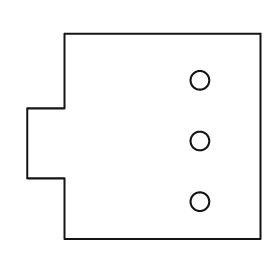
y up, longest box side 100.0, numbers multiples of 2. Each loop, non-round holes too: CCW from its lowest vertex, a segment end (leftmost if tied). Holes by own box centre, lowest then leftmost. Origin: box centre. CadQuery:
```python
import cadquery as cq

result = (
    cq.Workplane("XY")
    .moveTo(-34.0, -44.0)
    .lineTo(50.0, -44.0)
    .lineTo(50.0, 44.0)
    .lineTo(-34.0, 44.0)
    .lineTo(-34.0, 12.0)
    .lineTo(-50.0, 12.0)
    .lineTo(-50.0, -18.0)
    .lineTo(-34.0, -18.0)
    .close()
    .moveTo(24.0, -28.0)
    .circle(4.0)
    .moveTo(24.0, -2.0)
    .circle(4.0)
    .moveTo(24.0, 24.0)
    .circle(4.0)
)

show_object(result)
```